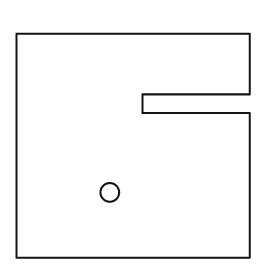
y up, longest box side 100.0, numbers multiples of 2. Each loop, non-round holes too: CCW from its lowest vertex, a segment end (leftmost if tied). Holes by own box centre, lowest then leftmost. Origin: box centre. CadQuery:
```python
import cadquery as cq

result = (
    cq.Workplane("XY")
    .moveTo(-50.0, -48.0)
    .lineTo(50.0, -48.0)
    .lineTo(50.0, 14.0)
    .lineTo(4.0, 14.0)
    .lineTo(4.0, 22.0)
    .lineTo(50.0, 22.0)
    .lineTo(50.0, 48.0)
    .lineTo(-50.0, 48.0)
    .close()
    .moveTo(-10.0, -20.0)
    .circle(4.0)
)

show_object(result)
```